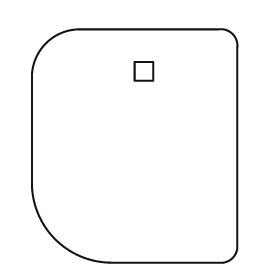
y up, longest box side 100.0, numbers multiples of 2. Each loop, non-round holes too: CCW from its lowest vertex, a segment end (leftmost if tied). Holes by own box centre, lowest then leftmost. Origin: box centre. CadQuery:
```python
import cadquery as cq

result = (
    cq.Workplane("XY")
    .moveTo(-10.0, -50.0)
    .lineTo(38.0, -50.0)
    .threePointArc((42.0, -48.0), (44.0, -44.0))
    .lineTo(44.0, 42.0)
    .threePointArc((42.0, 48.0), (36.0, 50.0))
    .lineTo(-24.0, 50.0)
    .threePointArc((-38.0, 44.0), (-44.0, 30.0))
    .lineTo(-44.0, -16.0)
    .threePointArc((-34.0, -40.0), (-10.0, -50.0))
    .close()
    .moveTo(0.0, 28.0)
    .lineTo(8.0, 28.0)
    .lineTo(8.0, 36.0)
    .lineTo(0.0, 36.0)
    .close()
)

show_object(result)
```